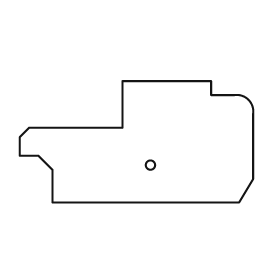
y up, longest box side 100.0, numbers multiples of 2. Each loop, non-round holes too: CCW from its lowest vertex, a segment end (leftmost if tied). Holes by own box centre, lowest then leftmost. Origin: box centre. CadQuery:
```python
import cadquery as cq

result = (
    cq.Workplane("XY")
    .moveTo(-36.0, -26.0)
    .lineTo(44.0, -26.0)
    .lineTo(50.0, -16.0)
    .lineTo(50.0, 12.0)
    .threePointArc((48.0, 18.0), (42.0, 20.0))
    .lineTo(32.0, 20.0)
    .lineTo(32.0, 26.0)
    .lineTo(-6.0, 26.0)
    .lineTo(-6.0, 6.0)
    .lineTo(-46.0, 6.0)
    .lineTo(-50.0, 2.0)
    .lineTo(-50.0, -6.0)
    .lineTo(-42.0, -6.0)
    .lineTo(-36.0, -12.0)
    .close()
    .moveTo(6.0, -10.0)
    .circle(2.0)
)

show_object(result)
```